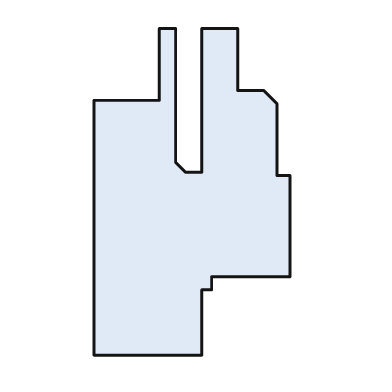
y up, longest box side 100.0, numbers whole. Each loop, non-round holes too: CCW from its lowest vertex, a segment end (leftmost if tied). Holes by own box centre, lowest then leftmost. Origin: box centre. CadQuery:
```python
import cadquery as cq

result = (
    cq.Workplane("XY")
    .moveTo(-30.0, -50.0)
    .lineTo(3.0, -50.0)
    .lineTo(3.0, -30.0)
    .lineTo(6.0, -30.0)
    .lineTo(6.0, -26.0)
    .lineTo(30.0, -26.0)
    .lineTo(30.0, 5.0)
    .lineTo(26.0, 5.0)
    .lineTo(26.0, 27.0)
    .lineTo(22.0, 31.0)
    .lineTo(14.0, 31.0)
    .lineTo(14.0, 50.0)
    .lineTo(3.0, 50.0)
    .lineTo(3.0, 6.0)
    .lineTo(-2.0, 6.0)
    .lineTo(-5.0, 9.0)
    .lineTo(-5.0, 50.0)
    .lineTo(-10.0, 50.0)
    .lineTo(-10.0, 28.0)
    .lineTo(-30.0, 28.0)
    .close()
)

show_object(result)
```